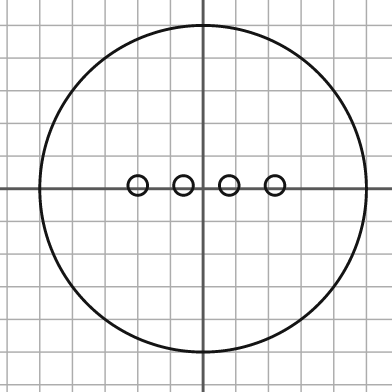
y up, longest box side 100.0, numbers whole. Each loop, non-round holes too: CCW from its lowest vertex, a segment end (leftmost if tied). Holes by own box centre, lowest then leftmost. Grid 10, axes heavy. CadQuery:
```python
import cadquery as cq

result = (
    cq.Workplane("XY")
    .moveTo(0.0, 0.0)
    .circle(50.0)
    .moveTo(-20.0, 1.0)
    .circle(3.0)
    .moveTo(-6.0, 1.0)
    .circle(3.0)
    .moveTo(8.0, 1.0)
    .circle(3.0)
    .moveTo(22.0, 1.0)
    .circle(3.0)
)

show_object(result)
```